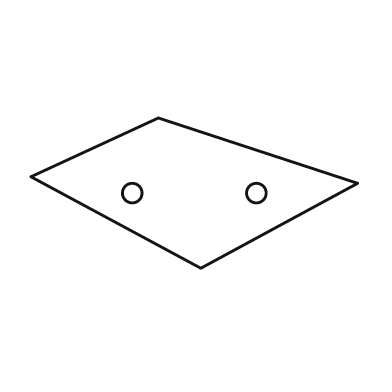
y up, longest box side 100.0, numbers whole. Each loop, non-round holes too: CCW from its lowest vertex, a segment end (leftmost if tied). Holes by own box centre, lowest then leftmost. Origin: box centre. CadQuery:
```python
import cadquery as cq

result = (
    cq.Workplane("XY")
    .moveTo(2.0, -23.0)
    .lineTo(50.0, 3.0)
    .lineTo(-11.0, 23.0)
    .lineTo(-50.0, 5.0)
    .close()
    .moveTo(-19.0, 0.0)
    .circle(3.0)
    .moveTo(19.0, 0.0)
    .circle(3.0)
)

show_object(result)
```